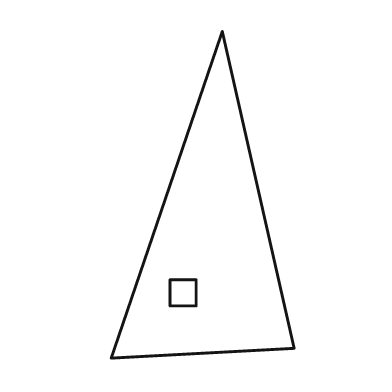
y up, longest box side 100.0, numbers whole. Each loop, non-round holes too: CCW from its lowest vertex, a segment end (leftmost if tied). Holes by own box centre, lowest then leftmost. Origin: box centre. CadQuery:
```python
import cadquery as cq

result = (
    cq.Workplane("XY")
    .moveTo(-28.0, -50.0)
    .lineTo(28.0, -47.0)
    .lineTo(6.0, 50.0)
    .close()
    .moveTo(-10.0, -34.0)
    .lineTo(-2.0, -34.0)
    .lineTo(-2.0, -26.0)
    .lineTo(-10.0, -26.0)
    .close()
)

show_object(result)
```